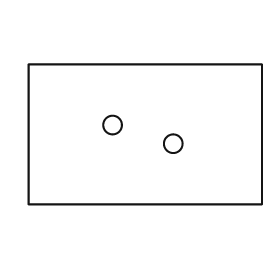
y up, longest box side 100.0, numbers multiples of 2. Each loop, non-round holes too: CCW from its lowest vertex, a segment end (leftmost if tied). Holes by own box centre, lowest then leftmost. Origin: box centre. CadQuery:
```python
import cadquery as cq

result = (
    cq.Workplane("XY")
    .moveTo(-50.0, -30.0)
    .lineTo(50.0, -30.0)
    .lineTo(50.0, 30.0)
    .lineTo(-50.0, 30.0)
    .close()
    .moveTo(12.0, -4.0)
    .circle(4.0)
    .moveTo(-14.0, 4.0)
    .circle(4.0)
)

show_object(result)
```